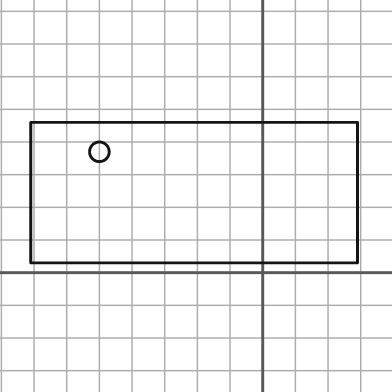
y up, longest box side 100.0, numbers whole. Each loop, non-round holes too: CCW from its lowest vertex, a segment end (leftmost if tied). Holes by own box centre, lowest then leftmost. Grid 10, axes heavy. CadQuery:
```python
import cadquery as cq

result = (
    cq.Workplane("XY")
    .moveTo(-71.0, 3.0)
    .lineTo(29.0, 3.0)
    .lineTo(29.0, 46.0)
    .lineTo(-71.0, 46.0)
    .close()
    .moveTo(-50.0, 37.0)
    .circle(3.0)
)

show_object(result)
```